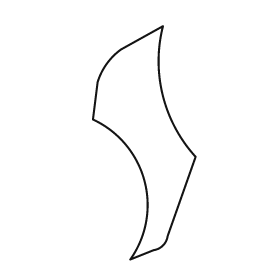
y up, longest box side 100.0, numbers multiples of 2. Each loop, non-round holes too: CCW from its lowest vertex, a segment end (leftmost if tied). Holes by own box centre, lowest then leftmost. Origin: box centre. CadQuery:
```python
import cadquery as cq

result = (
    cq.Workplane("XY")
    .moveTo(-6.0, -50.0)
    .lineTo(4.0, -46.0)
    .threePointArc((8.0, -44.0), (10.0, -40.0))
    .lineTo(22.0, -6.0)
    .threePointArc((8.0, 20.0), (8.0, 50.0))
    .lineTo(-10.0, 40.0)
    .threePointArc((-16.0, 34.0), (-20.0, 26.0))
    .lineTo(-22.0, 10.0)
    .threePointArc((0.0, -16.0), (-6.0, -50.0))
    .close()
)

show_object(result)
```